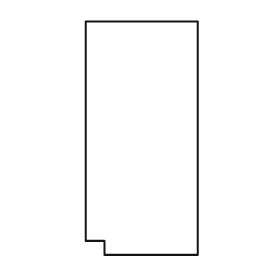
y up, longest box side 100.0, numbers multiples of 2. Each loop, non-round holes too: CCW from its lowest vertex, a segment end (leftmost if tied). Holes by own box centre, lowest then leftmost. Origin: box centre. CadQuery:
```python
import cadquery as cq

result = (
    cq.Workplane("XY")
    .moveTo(-16.0, -50.0)
    .lineTo(24.0, -50.0)
    .lineTo(24.0, 50.0)
    .lineTo(-24.0, 50.0)
    .lineTo(-24.0, -44.0)
    .lineTo(-16.0, -44.0)
    .close()
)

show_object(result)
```